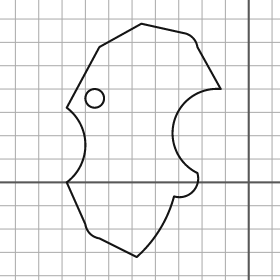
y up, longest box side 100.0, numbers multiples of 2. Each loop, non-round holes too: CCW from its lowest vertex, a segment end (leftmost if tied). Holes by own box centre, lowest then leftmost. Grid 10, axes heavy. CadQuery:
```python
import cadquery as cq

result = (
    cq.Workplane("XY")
    .moveTo(-48.0, -32.0)
    .threePointArc((-38.0, -20.0), (-32.0, -6.0))
    .threePointArc((-24.0, -4.0), (-22.0, 4.0))
    .threePointArc((-32.0, 26.0), (-12.0, 40.0))
    .lineTo(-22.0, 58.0)
    .threePointArc((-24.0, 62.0), (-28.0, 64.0))
    .lineTo(-46.0, 68.0)
    .lineTo(-64.0, 58.0)
    .lineTo(-78.0, 32.0)
    .threePointArc((-70.0, 16.0), (-78.0, 0.0))
    .lineTo(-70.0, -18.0)
    .threePointArc((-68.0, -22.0), (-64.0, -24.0))
    .close()
    .moveTo(-66.0, 36.0)
    .circle(4.0)
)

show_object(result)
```